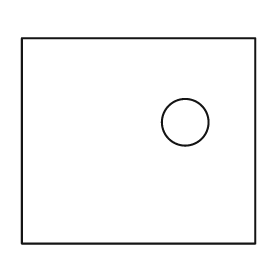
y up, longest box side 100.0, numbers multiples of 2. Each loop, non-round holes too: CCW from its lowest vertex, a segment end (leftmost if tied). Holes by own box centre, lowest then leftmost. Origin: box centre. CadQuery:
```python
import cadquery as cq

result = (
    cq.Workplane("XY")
    .moveTo(-50.0, -44.0)
    .lineTo(50.0, -44.0)
    .lineTo(50.0, 44.0)
    .lineTo(-50.0, 44.0)
    .close()
    .moveTo(20.0, 8.0)
    .circle(10.0)
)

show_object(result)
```